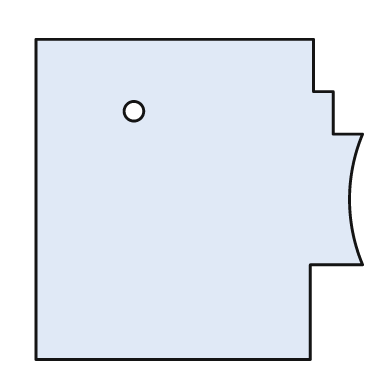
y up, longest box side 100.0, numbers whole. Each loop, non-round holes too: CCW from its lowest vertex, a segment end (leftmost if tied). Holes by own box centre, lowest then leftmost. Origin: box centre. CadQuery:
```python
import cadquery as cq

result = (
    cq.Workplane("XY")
    .moveTo(-50.0, -49.0)
    .lineTo(34.0, -49.0)
    .lineTo(34.0, -20.0)
    .lineTo(50.0, -20.0)
    .threePointArc((46.0, 0.0), (50.0, 20.0))
    .lineTo(41.0, 20.0)
    .lineTo(41.0, 33.0)
    .lineTo(35.0, 33.0)
    .lineTo(35.0, 49.0)
    .lineTo(-50.0, 49.0)
    .close()
    .moveTo(-20.0, 27.0)
    .circle(3.0)
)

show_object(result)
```